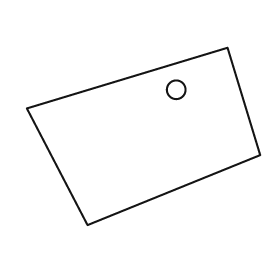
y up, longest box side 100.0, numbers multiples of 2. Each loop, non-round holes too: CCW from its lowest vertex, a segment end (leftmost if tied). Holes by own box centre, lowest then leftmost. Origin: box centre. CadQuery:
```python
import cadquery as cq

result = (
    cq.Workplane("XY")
    .moveTo(-24.0, -38.0)
    .lineTo(50.0, -8.0)
    .lineTo(36.0, 38.0)
    .lineTo(-50.0, 12.0)
    .close()
    .moveTo(14.0, 20.0)
    .circle(4.0)
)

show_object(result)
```